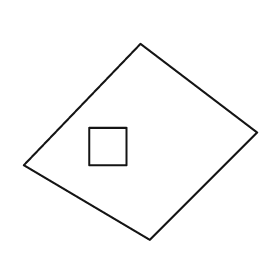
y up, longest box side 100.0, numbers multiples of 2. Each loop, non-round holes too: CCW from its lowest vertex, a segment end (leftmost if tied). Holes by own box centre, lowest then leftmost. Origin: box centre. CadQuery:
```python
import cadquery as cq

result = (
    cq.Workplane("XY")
    .moveTo(4.0, -42.0)
    .lineTo(50.0, 4.0)
    .lineTo(0.0, 42.0)
    .lineTo(-50.0, -10.0)
    .close()
    .moveTo(-22.0, -10.0)
    .lineTo(-6.0, -10.0)
    .lineTo(-6.0, 6.0)
    .lineTo(-22.0, 6.0)
    .close()
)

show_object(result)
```